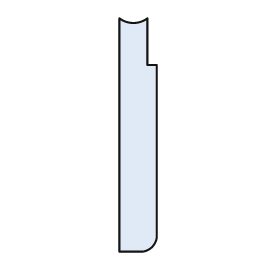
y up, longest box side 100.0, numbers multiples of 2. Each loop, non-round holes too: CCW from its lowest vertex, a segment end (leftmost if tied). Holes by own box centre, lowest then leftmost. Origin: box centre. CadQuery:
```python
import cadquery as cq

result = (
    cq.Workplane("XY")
    .moveTo(-8.0, -50.0)
    .lineTo(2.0, -50.0)
    .threePointArc((6.0, -48.0), (8.0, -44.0))
    .lineTo(8.0, 30.0)
    .lineTo(4.0, 30.0)
    .lineTo(4.0, 50.0)
    .threePointArc((-2.0, 48.0), (-8.0, 50.0))
    .close()
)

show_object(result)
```